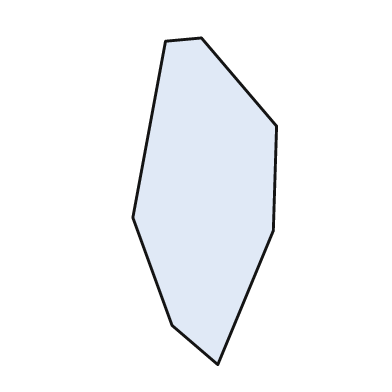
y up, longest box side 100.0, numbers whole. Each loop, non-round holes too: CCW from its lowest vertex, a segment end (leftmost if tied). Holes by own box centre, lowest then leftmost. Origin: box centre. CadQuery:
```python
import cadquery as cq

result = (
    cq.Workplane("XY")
    .moveTo(4.0, -50.0)
    .lineTo(21.0, -9.0)
    .lineTo(22.0, 23.0)
    .lineTo(-1.0, 50.0)
    .lineTo(-12.0, 49.0)
    .lineTo(-22.0, -5.0)
    .lineTo(-10.0, -38.0)
    .close()
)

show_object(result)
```